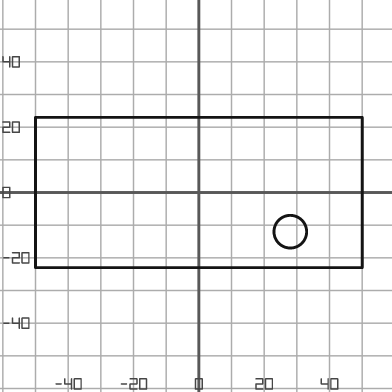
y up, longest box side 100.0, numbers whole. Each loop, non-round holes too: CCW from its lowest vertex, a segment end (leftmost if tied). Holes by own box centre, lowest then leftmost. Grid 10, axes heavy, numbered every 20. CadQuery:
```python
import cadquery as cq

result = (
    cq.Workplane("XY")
    .moveTo(-50.0, -23.0)
    .lineTo(50.0, -23.0)
    .lineTo(50.0, 23.0)
    .lineTo(-50.0, 23.0)
    .close()
    .moveTo(28.0, -12.0)
    .circle(5.0)
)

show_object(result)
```